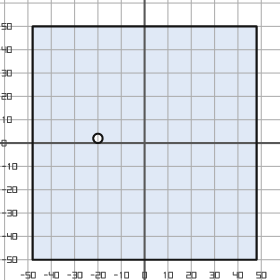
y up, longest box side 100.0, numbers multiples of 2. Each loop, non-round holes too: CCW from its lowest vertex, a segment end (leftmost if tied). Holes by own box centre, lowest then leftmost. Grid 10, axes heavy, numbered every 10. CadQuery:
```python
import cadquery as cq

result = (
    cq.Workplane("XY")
    .moveTo(-48.0, -50.0)
    .lineTo(48.0, -50.0)
    .lineTo(48.0, 50.0)
    .lineTo(-48.0, 50.0)
    .close()
    .moveTo(-20.0, 2.0)
    .circle(2.0)
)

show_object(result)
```